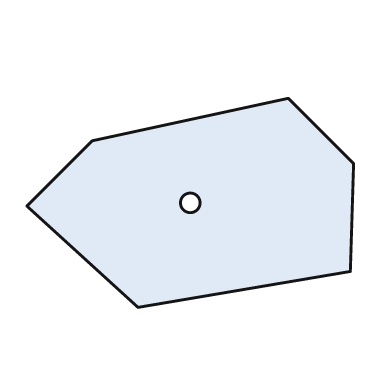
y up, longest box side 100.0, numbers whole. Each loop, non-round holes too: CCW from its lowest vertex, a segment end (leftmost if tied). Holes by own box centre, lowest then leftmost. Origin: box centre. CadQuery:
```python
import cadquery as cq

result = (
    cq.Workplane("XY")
    .moveTo(-16.0, -32.0)
    .lineTo(49.0, -21.0)
    .lineTo(50.0, 12.0)
    .lineTo(30.0, 32.0)
    .lineTo(-30.0, 19.0)
    .lineTo(-50.0, -1.0)
    .close()
    .moveTo(0.0, 0.0)
    .circle(3.0)
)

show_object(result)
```